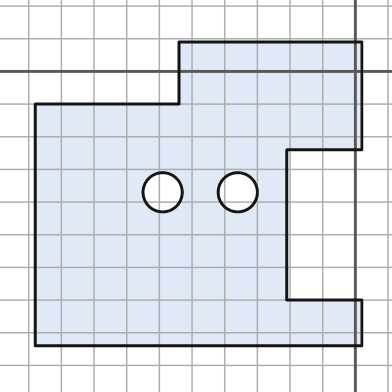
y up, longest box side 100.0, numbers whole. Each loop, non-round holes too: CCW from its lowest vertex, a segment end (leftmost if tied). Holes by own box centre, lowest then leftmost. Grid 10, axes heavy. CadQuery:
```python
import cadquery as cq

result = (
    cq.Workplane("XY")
    .moveTo(-98.0, -84.0)
    .lineTo(2.0, -84.0)
    .lineTo(2.0, -70.0)
    .lineTo(-21.0, -70.0)
    .lineTo(-21.0, -24.0)
    .lineTo(2.0, -24.0)
    .lineTo(2.0, 9.0)
    .lineTo(-54.0, 9.0)
    .lineTo(-54.0, -10.0)
    .lineTo(-98.0, -10.0)
    .close()
    .moveTo(-59.0, -37.0)
    .circle(6.0)
    .moveTo(-36.0, -37.0)
    .circle(6.0)
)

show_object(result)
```